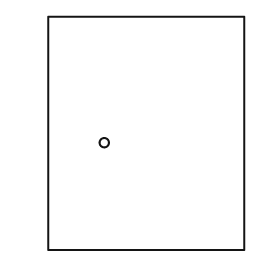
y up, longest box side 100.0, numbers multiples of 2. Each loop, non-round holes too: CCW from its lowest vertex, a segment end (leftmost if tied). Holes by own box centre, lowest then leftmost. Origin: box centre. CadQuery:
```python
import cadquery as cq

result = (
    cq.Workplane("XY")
    .moveTo(-42.0, -50.0)
    .lineTo(42.0, -50.0)
    .lineTo(42.0, 50.0)
    .lineTo(-42.0, 50.0)
    .close()
    .moveTo(-18.0, -4.0)
    .circle(2.0)
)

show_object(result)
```